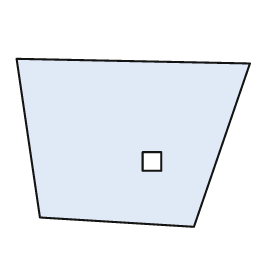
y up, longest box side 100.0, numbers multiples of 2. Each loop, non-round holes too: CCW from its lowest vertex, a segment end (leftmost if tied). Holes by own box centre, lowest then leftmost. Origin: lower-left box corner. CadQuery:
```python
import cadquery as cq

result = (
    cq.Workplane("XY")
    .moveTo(76.0, 0.0)
    .lineTo(100.0, 70.0)
    .lineTo(0.0, 72.0)
    .lineTo(10.0, 4.0)
    .close()
    .moveTo(54.0, 24.0)
    .lineTo(62.0, 24.0)
    .lineTo(62.0, 32.0)
    .lineTo(54.0, 32.0)
    .close()
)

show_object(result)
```